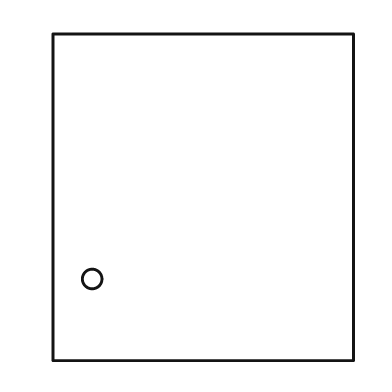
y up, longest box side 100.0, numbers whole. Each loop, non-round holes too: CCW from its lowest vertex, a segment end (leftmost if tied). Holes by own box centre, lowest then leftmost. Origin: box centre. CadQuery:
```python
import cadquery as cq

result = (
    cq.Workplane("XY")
    .moveTo(-46.0, -50.0)
    .lineTo(46.0, -50.0)
    .lineTo(46.0, 50.0)
    .lineTo(-46.0, 50.0)
    .close()
    .moveTo(-34.0, -25.0)
    .circle(3.0)
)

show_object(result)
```